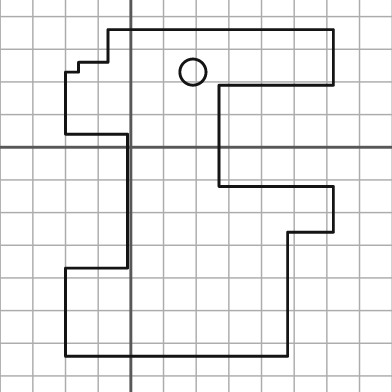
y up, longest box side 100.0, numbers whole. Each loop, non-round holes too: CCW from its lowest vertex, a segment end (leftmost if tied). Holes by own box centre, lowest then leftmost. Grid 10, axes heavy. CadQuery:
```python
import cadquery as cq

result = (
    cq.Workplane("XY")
    .moveTo(-20.0, -64.0)
    .lineTo(48.0, -64.0)
    .lineTo(48.0, -26.0)
    .lineTo(62.0, -26.0)
    .lineTo(62.0, -12.0)
    .lineTo(27.0, -12.0)
    .lineTo(27.0, 19.0)
    .lineTo(62.0, 19.0)
    .lineTo(62.0, 36.0)
    .lineTo(-7.0, 36.0)
    .lineTo(-7.0, 26.0)
    .lineTo(-16.0, 26.0)
    .lineTo(-16.0, 23.0)
    .lineTo(-20.0, 23.0)
    .lineTo(-20.0, 4.0)
    .lineTo(-1.0, 4.0)
    .lineTo(-1.0, -37.0)
    .lineTo(-20.0, -37.0)
    .close()
    .moveTo(19.0, 23.0)
    .circle(4.0)
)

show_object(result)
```